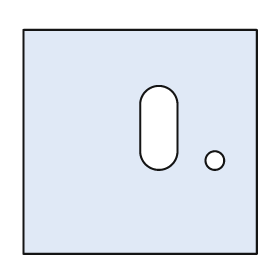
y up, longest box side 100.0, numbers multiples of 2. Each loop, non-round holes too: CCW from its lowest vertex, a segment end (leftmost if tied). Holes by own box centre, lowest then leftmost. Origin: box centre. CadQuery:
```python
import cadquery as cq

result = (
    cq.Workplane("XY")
    .moveTo(-50.0, -48.0)
    .lineTo(50.0, -48.0)
    .lineTo(50.0, 48.0)
    .lineTo(-50.0, 48.0)
    .close()
    .moveTo(32.0, -8.0)
    .circle(4.0)
    .moveTo(0.0, -4.0)
    .threePointArc((8.0, -12.0), (16.0, -4.0))
    .lineTo(16.0, 16.0)
    .threePointArc((8.0, 24.0), (0.0, 16.0))
    .close()
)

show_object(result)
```